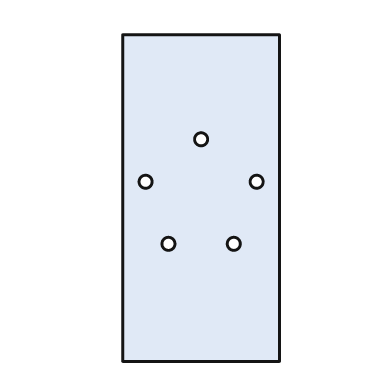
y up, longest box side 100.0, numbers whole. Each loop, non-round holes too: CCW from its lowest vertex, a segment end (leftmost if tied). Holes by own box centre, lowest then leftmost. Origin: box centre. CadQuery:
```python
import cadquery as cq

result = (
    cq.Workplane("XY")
    .moveTo(-24.0, -50.0)
    .lineTo(24.0, -50.0)
    .lineTo(24.0, 50.0)
    .lineTo(-24.0, 50.0)
    .close()
    .moveTo(-10.0, -14.0)
    .circle(2.0)
    .moveTo(10.0, -14.0)
    .circle(2.0)
    .moveTo(-17.0, 5.0)
    .circle(2.0)
    .moveTo(17.0, 5.0)
    .circle(2.0)
    .moveTo(0.0, 18.0)
    .circle(2.0)
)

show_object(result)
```